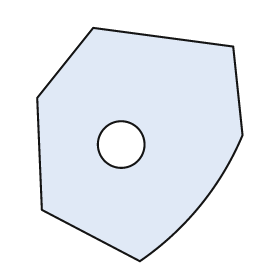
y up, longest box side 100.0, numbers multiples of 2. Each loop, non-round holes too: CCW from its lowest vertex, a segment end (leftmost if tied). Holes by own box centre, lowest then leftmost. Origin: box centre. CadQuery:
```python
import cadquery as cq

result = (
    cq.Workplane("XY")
    .moveTo(0.0, -50.0)
    .threePointArc((26.0, -26.0), (44.0, 4.0))
    .lineTo(40.0, 42.0)
    .lineTo(-20.0, 50.0)
    .lineTo(-44.0, 20.0)
    .lineTo(-42.0, -28.0)
    .close()
    .moveTo(-8.0, 0.0)
    .circle(10.0)
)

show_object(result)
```